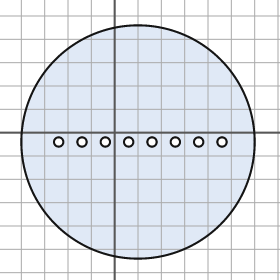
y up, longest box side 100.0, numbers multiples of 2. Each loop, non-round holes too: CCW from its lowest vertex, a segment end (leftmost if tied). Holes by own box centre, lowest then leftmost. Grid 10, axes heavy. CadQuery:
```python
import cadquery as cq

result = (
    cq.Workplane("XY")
    .moveTo(10.0, -4.0)
    .circle(50.0)
    .moveTo(-24.0, -4.0)
    .circle(2.0)
    .moveTo(-14.0, -4.0)
    .circle(2.0)
    .moveTo(-4.0, -4.0)
    .circle(2.0)
    .moveTo(6.0, -4.0)
    .circle(2.0)
    .moveTo(16.0, -4.0)
    .circle(2.0)
    .moveTo(26.0, -4.0)
    .circle(2.0)
    .moveTo(36.0, -4.0)
    .circle(2.0)
    .moveTo(46.0, -4.0)
    .circle(2.0)
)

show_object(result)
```